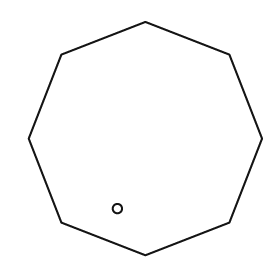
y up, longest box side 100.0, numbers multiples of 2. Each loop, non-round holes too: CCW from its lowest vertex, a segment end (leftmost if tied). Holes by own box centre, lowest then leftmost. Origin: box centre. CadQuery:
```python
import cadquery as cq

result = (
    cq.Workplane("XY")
    .moveTo(0.0, -50.0)
    .lineTo(36.0, -36.0)
    .lineTo(50.0, 0.0)
    .lineTo(36.0, 36.0)
    .lineTo(0.0, 50.0)
    .lineTo(-36.0, 36.0)
    .lineTo(-50.0, 0.0)
    .lineTo(-36.0, -36.0)
    .close()
    .moveTo(-12.0, -30.0)
    .circle(2.0)
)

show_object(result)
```